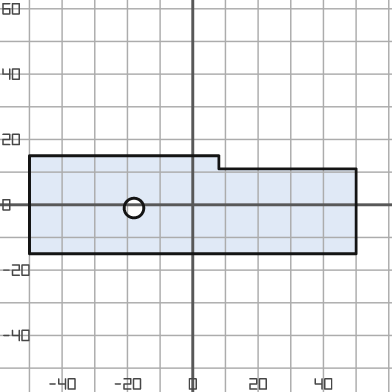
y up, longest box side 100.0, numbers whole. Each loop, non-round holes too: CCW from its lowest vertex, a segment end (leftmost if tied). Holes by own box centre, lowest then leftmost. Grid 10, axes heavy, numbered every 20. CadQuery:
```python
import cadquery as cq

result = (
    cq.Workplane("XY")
    .moveTo(-50.0, -15.0)
    .lineTo(50.0, -15.0)
    .lineTo(50.0, 11.0)
    .lineTo(8.0, 11.0)
    .lineTo(8.0, 15.0)
    .lineTo(-50.0, 15.0)
    .close()
    .moveTo(-18.0, -1.0)
    .circle(3.0)
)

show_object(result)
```